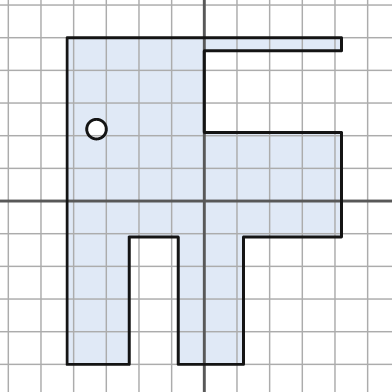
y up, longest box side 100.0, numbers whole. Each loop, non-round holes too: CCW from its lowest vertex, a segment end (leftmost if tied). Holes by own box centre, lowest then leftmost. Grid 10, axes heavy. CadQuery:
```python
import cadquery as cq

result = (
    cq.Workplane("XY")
    .moveTo(-42.0, -50.0)
    .lineTo(-23.0, -50.0)
    .lineTo(-23.0, -11.0)
    .lineTo(-8.0, -11.0)
    .lineTo(-8.0, -50.0)
    .lineTo(12.0, -50.0)
    .lineTo(12.0, -11.0)
    .lineTo(42.0, -11.0)
    .lineTo(42.0, 21.0)
    .lineTo(0.0, 21.0)
    .lineTo(0.0, 46.0)
    .lineTo(42.0, 46.0)
    .lineTo(42.0, 50.0)
    .lineTo(-42.0, 50.0)
    .close()
    .moveTo(-33.0, 22.0)
    .circle(3.0)
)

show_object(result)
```